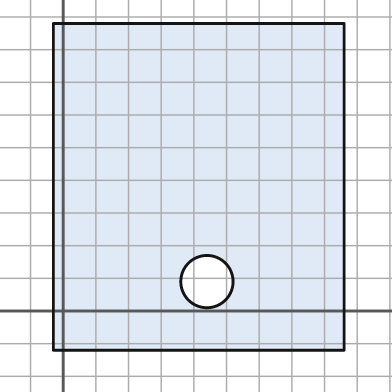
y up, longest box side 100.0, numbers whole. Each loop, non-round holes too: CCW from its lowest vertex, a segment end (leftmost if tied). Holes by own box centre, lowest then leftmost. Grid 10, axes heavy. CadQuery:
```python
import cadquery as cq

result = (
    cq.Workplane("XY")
    .moveTo(-3.0, -12.0)
    .lineTo(86.0, -12.0)
    .lineTo(86.0, 88.0)
    .lineTo(-3.0, 88.0)
    .close()
    .moveTo(44.0, 9.0)
    .circle(8.0)
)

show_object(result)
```